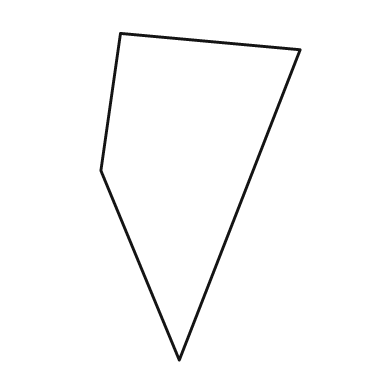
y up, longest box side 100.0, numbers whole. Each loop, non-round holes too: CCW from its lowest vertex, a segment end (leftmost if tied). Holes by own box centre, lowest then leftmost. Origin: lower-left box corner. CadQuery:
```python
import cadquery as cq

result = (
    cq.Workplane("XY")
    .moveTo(24.0, 0.0)
    .lineTo(61.0, 95.0)
    .lineTo(6.0, 100.0)
    .lineTo(0.0, 58.0)
    .close()
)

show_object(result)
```